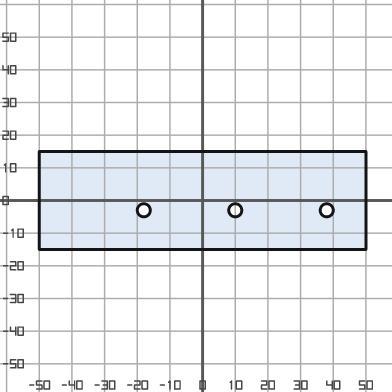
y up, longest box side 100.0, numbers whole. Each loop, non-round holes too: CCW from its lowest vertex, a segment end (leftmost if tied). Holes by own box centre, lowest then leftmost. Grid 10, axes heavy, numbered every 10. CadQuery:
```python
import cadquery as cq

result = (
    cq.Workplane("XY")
    .moveTo(-50.0, -15.0)
    .lineTo(50.0, -15.0)
    .lineTo(50.0, 15.0)
    .lineTo(-50.0, 15.0)
    .close()
    .moveTo(-18.0, -3.0)
    .circle(2.0)
    .moveTo(10.0, -3.0)
    .circle(2.0)
    .moveTo(38.0, -3.0)
    .circle(2.0)
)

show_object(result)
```